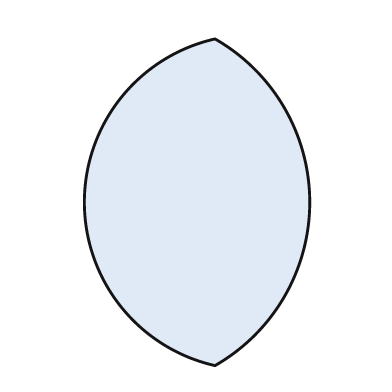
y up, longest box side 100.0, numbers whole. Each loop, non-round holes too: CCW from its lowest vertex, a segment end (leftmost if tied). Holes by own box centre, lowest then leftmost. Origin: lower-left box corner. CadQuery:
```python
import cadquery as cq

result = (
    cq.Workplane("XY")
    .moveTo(40.0, 0.0)
    .threePointArc((69.0, 50.0), (40.0, 100.0))
    .threePointArc((0.0, 50.0), (40.0, 0.0))
    .close()
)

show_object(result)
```